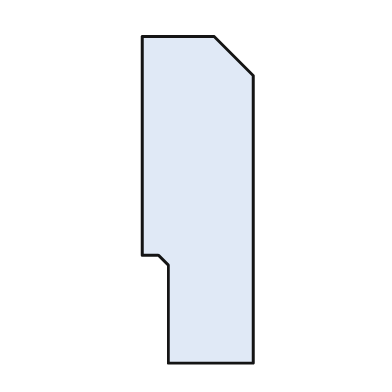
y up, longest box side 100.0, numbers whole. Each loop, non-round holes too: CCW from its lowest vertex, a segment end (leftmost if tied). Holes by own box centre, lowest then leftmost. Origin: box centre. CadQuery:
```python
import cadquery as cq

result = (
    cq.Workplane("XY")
    .moveTo(-9.0, -50.0)
    .lineTo(17.0, -50.0)
    .lineTo(17.0, 38.0)
    .lineTo(5.0, 50.0)
    .lineTo(-17.0, 50.0)
    .lineTo(-17.0, -17.0)
    .lineTo(-12.0, -17.0)
    .lineTo(-9.0, -20.0)
    .close()
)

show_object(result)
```